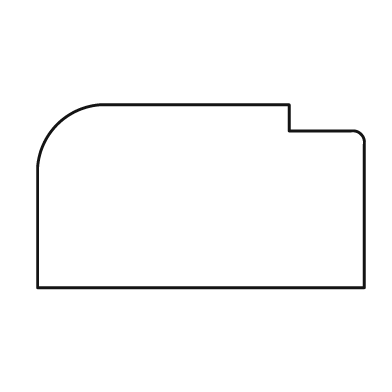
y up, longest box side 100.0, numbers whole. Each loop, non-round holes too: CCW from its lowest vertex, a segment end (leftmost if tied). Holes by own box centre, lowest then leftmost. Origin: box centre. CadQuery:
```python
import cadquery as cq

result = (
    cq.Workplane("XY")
    .moveTo(-50.0, -28.0)
    .lineTo(50.0, -28.0)
    .lineTo(50.0, 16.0)
    .threePointArc((49.0, 19.0), (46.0, 20.0))
    .lineTo(27.0, 20.0)
    .lineTo(27.0, 28.0)
    .lineTo(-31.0, 28.0)
    .threePointArc((-44.0, 22.0), (-50.0, 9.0))
    .close()
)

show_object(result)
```